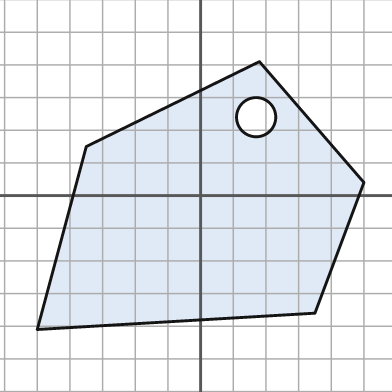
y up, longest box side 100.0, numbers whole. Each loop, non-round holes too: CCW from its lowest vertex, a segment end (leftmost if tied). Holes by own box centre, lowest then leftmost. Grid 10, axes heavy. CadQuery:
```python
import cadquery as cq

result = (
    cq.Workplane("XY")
    .moveTo(-50.0, -41.0)
    .lineTo(35.0, -36.0)
    .lineTo(50.0, 4.0)
    .lineTo(18.0, 41.0)
    .lineTo(-35.0, 15.0)
    .close()
    .moveTo(17.0, 24.0)
    .circle(6.0)
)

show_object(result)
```